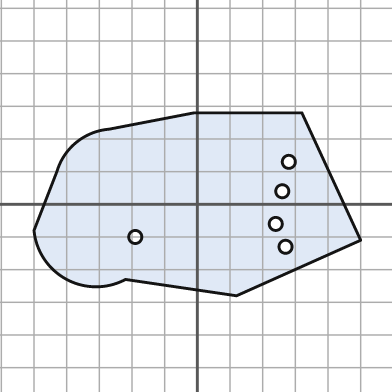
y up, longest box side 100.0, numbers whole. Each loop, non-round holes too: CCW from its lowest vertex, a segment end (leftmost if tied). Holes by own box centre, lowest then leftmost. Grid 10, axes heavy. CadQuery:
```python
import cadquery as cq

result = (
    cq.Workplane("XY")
    .moveTo(12.0, -28.0)
    .lineTo(50.0, -11.0)
    .lineTo(32.0, 28.0)
    .lineTo(-1.0, 28.0)
    .lineTo(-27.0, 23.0)
    .threePointArc((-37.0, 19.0), (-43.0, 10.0))
    .lineTo(-50.0, -8.0)
    .threePointArc((-40.0, -23.0), (-22.0, -23.0))
    .close()
    .moveTo(27.0, -13.0)
    .circle(2.0)
    .moveTo(-19.0, -10.0)
    .circle(2.0)
    .moveTo(24.0, -6.0)
    .circle(2.0)
    .moveTo(26.0, 4.0)
    .circle(2.0)
    .moveTo(28.0, 13.0)
    .circle(2.0)
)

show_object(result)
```